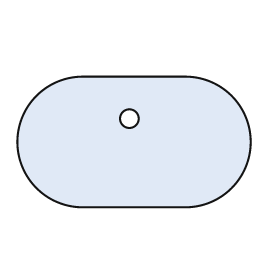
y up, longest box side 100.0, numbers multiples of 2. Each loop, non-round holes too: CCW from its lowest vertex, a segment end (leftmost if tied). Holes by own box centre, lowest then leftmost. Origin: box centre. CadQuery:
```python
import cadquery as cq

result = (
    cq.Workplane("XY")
    .moveTo(-22.0, -28.0)
    .lineTo(22.0, -28.0)
    .threePointArc((50.0, 0.0), (22.0, 28.0))
    .lineTo(-22.0, 28.0)
    .threePointArc((-50.0, 0.0), (-22.0, -28.0))
    .close()
    .moveTo(-2.0, 10.0)
    .circle(4.0)
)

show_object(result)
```